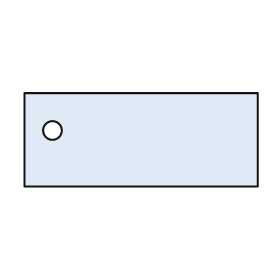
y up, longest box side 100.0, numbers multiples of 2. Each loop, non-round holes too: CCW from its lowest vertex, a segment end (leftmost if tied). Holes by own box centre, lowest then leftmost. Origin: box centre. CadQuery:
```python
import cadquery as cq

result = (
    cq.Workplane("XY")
    .moveTo(-50.0, -20.0)
    .lineTo(50.0, -20.0)
    .lineTo(50.0, 20.0)
    .lineTo(-50.0, 20.0)
    .close()
    .moveTo(-38.0, 4.0)
    .circle(4.0)
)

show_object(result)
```